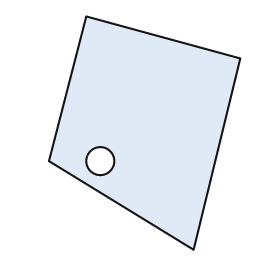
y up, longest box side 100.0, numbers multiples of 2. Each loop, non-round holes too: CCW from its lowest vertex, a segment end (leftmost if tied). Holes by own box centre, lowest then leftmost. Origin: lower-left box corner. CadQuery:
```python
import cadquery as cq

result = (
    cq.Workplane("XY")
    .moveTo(62.0, 0.0)
    .lineTo(82.0, 82.0)
    .lineTo(16.0, 100.0)
    .lineTo(0.0, 38.0)
    .close()
    .moveTo(22.0, 38.0)
    .circle(6.0)
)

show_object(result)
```